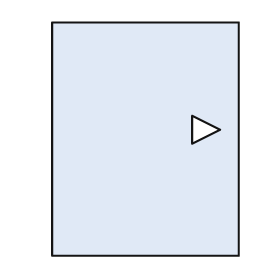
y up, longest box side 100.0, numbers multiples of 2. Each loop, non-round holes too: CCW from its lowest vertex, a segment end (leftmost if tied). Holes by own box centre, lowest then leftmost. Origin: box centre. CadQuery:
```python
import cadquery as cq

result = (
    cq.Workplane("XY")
    .moveTo(-40.0, -50.0)
    .lineTo(40.0, -50.0)
    .lineTo(40.0, 50.0)
    .lineTo(-40.0, 50.0)
    .close()
    .moveTo(20.0, -2.0)
    .lineTo(32.0, 4.0)
    .lineTo(20.0, 10.0)
    .close()
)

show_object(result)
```